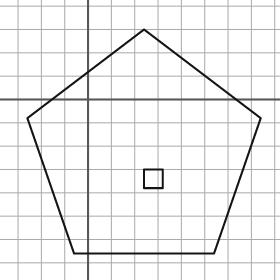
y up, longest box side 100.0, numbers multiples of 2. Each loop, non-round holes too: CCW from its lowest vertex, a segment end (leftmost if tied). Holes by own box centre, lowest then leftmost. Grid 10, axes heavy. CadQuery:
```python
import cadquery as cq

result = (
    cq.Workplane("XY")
    .moveTo(-6.0, -66.0)
    .lineTo(54.0, -66.0)
    .lineTo(74.0, -8.0)
    .lineTo(24.0, 30.0)
    .lineTo(-26.0, -8.0)
    .close()
    .moveTo(24.0, -38.0)
    .lineTo(32.0, -38.0)
    .lineTo(32.0, -30.0)
    .lineTo(24.0, -30.0)
    .close()
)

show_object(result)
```